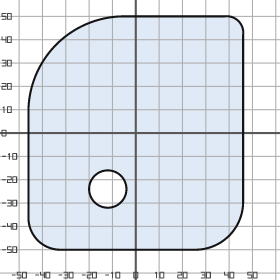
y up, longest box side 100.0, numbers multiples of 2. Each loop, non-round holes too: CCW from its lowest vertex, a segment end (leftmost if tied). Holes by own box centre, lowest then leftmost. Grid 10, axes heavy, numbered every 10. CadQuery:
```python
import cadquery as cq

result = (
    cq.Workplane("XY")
    .moveTo(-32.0, -50.0)
    .lineTo(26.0, -50.0)
    .threePointArc((40.0, -44.0), (46.0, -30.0))
    .lineTo(46.0, 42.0)
    .threePointArc((44.0, 48.0), (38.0, 50.0))
    .lineTo(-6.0, 50.0)
    .threePointArc((-34.0, 38.0), (-46.0, 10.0))
    .lineTo(-46.0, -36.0)
    .threePointArc((-42.0, -46.0), (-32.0, -50.0))
    .close()
    .moveTo(-12.0, -24.0)
    .circle(8.0)
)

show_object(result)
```